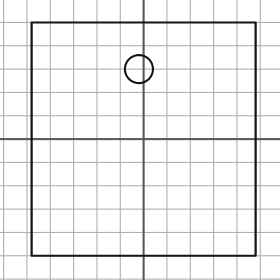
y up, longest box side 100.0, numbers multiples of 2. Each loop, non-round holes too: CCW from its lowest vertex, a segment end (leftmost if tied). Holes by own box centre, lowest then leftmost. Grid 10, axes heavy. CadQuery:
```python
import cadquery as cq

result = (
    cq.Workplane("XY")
    .moveTo(-48.0, -50.0)
    .lineTo(48.0, -50.0)
    .lineTo(48.0, 50.0)
    .lineTo(-48.0, 50.0)
    .close()
    .moveTo(-2.0, 30.0)
    .circle(6.0)
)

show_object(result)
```